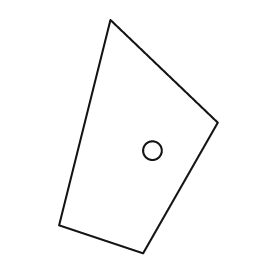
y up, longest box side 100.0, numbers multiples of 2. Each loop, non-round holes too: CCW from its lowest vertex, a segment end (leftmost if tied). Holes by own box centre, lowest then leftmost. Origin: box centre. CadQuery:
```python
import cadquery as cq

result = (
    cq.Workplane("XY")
    .moveTo(2.0, -50.0)
    .lineTo(34.0, 6.0)
    .lineTo(-12.0, 50.0)
    .lineTo(-34.0, -38.0)
    .close()
    .moveTo(6.0, -6.0)
    .circle(4.0)
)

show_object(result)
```